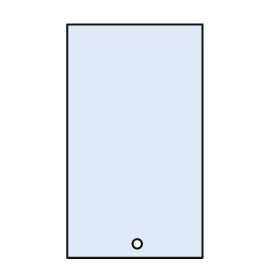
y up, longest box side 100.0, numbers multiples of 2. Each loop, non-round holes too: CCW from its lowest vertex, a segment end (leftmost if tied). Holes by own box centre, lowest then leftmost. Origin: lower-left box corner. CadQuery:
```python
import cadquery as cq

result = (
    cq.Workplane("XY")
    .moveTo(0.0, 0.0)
    .lineTo(58.0, 0.0)
    .lineTo(58.0, 100.0)
    .lineTo(0.0, 100.0)
    .close()
    .moveTo(30.0, 6.0)
    .circle(2.0)
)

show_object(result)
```